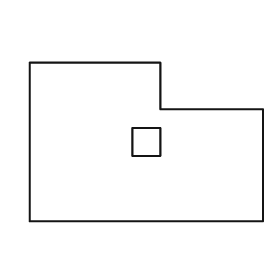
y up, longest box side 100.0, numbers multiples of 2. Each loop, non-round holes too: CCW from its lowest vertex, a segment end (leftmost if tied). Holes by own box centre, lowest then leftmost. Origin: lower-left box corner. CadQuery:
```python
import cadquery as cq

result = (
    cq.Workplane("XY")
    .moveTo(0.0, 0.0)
    .lineTo(100.0, 0.0)
    .lineTo(100.0, 48.0)
    .lineTo(56.0, 48.0)
    .lineTo(56.0, 68.0)
    .lineTo(0.0, 68.0)
    .close()
    .moveTo(44.0, 28.0)
    .lineTo(56.0, 28.0)
    .lineTo(56.0, 40.0)
    .lineTo(44.0, 40.0)
    .close()
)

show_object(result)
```